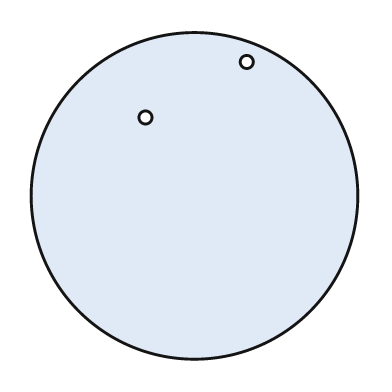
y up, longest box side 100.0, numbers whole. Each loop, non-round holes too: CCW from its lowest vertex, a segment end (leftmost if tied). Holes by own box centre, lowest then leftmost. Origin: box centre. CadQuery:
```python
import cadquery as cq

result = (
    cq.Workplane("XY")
    .moveTo(0.0, 0.0)
    .circle(50.0)
    .moveTo(-15.0, 24.0)
    .circle(2.0)
    .moveTo(16.0, 41.0)
    .circle(2.0)
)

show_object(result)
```